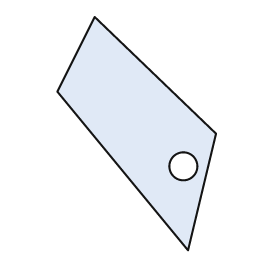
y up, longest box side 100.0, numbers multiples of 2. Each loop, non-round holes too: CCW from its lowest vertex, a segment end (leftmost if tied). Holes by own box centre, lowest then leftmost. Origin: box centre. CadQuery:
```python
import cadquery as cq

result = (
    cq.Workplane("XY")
    .moveTo(22.0, -50.0)
    .lineTo(34.0, 0.0)
    .lineTo(-18.0, 50.0)
    .lineTo(-34.0, 18.0)
    .close()
    .moveTo(20.0, -14.0)
    .circle(6.0)
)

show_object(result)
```